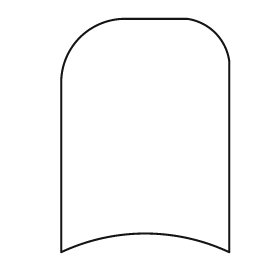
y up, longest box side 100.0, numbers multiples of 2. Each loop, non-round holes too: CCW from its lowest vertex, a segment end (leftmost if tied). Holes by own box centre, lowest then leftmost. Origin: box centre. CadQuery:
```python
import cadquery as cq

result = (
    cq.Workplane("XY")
    .moveTo(-36.0, -50.0)
    .threePointArc((0.0, -42.0), (36.0, -50.0))
    .lineTo(36.0, 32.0)
    .threePointArc((30.0, 44.0), (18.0, 50.0))
    .lineTo(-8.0, 50.0)
    .threePointArc((-28.0, 42.0), (-36.0, 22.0))
    .close()
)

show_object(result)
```